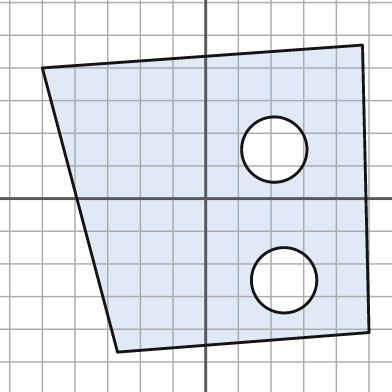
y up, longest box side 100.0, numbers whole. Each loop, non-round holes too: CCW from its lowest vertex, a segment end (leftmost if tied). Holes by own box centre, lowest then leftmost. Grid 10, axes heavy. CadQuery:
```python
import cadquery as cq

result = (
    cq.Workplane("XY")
    .moveTo(-27.0, -47.0)
    .lineTo(50.0, -41.0)
    .lineTo(48.0, 47.0)
    .lineTo(-50.0, 40.0)
    .close()
    .moveTo(24.0, -25.0)
    .circle(10.0)
    .moveTo(21.0, 15.0)
    .circle(10.0)
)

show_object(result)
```